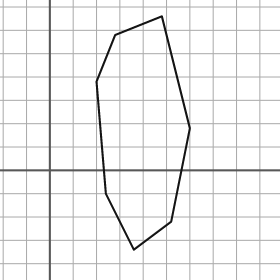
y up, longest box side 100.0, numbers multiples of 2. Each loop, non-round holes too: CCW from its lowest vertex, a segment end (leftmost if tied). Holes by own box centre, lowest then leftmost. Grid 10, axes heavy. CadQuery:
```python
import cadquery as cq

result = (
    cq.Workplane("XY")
    .moveTo(36.0, -34.0)
    .lineTo(52.0, -22.0)
    .lineTo(60.0, 18.0)
    .lineTo(48.0, 66.0)
    .lineTo(28.0, 58.0)
    .lineTo(20.0, 38.0)
    .lineTo(24.0, -10.0)
    .close()
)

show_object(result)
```